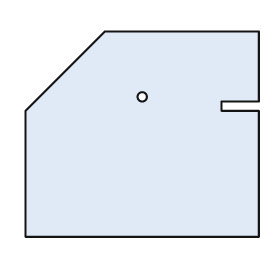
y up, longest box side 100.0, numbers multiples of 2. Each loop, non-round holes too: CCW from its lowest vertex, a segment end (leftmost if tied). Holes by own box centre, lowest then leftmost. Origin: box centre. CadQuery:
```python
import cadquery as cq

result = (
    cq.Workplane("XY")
    .moveTo(-50.0, -44.0)
    .lineTo(50.0, -44.0)
    .lineTo(50.0, 10.0)
    .lineTo(34.0, 10.0)
    .lineTo(34.0, 14.0)
    .lineTo(50.0, 14.0)
    .lineTo(50.0, 44.0)
    .lineTo(-16.0, 44.0)
    .lineTo(-50.0, 10.0)
    .close()
    .moveTo(0.0, 16.0)
    .circle(2.0)
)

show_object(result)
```